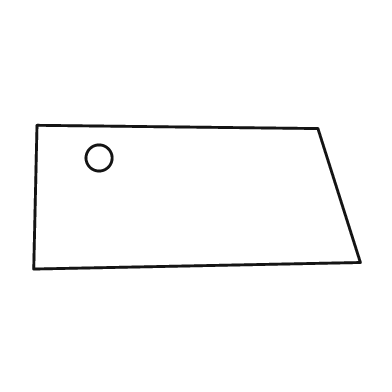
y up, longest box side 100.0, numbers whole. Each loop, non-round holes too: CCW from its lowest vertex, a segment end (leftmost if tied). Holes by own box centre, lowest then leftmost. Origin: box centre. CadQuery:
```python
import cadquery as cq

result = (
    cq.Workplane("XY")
    .moveTo(-50.0, -22.0)
    .lineTo(50.0, -20.0)
    .lineTo(37.0, 21.0)
    .lineTo(-49.0, 22.0)
    .close()
    .moveTo(-30.0, 12.0)
    .circle(4.0)
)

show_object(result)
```